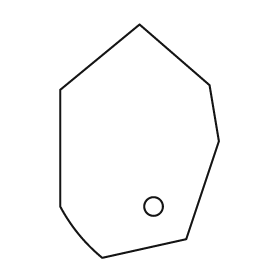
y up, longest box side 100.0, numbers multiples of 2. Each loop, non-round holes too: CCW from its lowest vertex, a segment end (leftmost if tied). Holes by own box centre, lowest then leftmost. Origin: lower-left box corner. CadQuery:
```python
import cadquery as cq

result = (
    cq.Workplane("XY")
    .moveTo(18.0, 0.0)
    .lineTo(54.0, 8.0)
    .lineTo(68.0, 50.0)
    .lineTo(64.0, 74.0)
    .lineTo(34.0, 100.0)
    .lineTo(0.0, 72.0)
    .lineTo(0.0, 22.0)
    .threePointArc((8.0, 10.0), (18.0, 0.0))
    .close()
    .moveTo(40.0, 22.0)
    .circle(4.0)
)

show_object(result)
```